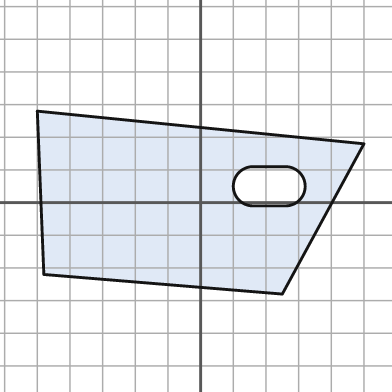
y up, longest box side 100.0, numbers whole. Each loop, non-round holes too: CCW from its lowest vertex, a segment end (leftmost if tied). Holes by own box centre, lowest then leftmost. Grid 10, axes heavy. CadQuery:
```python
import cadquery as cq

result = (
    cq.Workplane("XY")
    .moveTo(25.0, -28.0)
    .lineTo(50.0, 18.0)
    .lineTo(-50.0, 28.0)
    .lineTo(-48.0, -22.0)
    .close()
    .moveTo(16.0, -1.0)
    .lineTo(26.0, -1.0)
    .threePointArc((32.0, 5.0), (26.0, 11.0))
    .lineTo(16.0, 11.0)
    .threePointArc((10.0, 5.0), (16.0, -1.0))
    .close()
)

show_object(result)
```